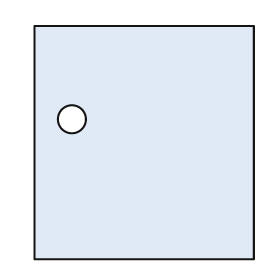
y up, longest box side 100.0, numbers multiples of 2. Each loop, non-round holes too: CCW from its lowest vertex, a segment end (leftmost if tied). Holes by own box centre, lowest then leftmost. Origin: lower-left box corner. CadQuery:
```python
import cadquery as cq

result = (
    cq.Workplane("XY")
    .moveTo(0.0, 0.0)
    .lineTo(94.0, 0.0)
    .lineTo(94.0, 100.0)
    .lineTo(0.0, 100.0)
    .close()
    .moveTo(16.0, 60.0)
    .circle(6.0)
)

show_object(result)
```